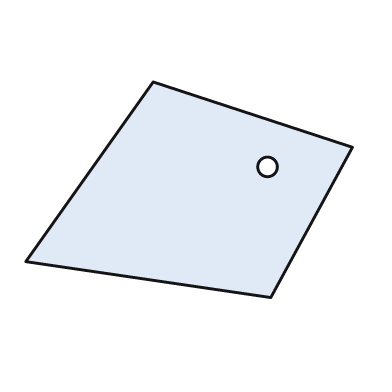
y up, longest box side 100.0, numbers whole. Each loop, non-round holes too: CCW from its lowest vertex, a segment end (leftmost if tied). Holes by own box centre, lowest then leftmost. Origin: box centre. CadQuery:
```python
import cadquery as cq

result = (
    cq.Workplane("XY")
    .moveTo(25.0, -33.0)
    .lineTo(50.0, 13.0)
    .lineTo(-11.0, 33.0)
    .lineTo(-50.0, -22.0)
    .close()
    .moveTo(24.0, 7.0)
    .circle(3.0)
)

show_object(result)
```